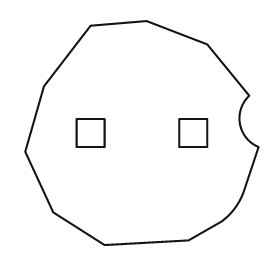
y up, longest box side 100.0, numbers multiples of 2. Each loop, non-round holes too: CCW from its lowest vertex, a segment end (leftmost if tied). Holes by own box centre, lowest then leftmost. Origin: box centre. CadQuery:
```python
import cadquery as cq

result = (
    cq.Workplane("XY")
    .moveTo(-16.0, -48.0)
    .lineTo(20.0, -46.0)
    .lineTo(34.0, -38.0)
    .threePointArc((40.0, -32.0), (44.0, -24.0))
    .lineTo(50.0, -6.0)
    .threePointArc((42.0, 4.0), (46.0, 16.0))
    .lineTo(28.0, 38.0)
    .lineTo(2.0, 48.0)
    .lineTo(-22.0, 46.0)
    .lineTo(-42.0, 20.0)
    .lineTo(-50.0, -8.0)
    .lineTo(-38.0, -34.0)
    .close()
    .moveTo(-28.0, -6.0)
    .lineTo(-16.0, -6.0)
    .lineTo(-16.0, 6.0)
    .lineTo(-28.0, 6.0)
    .close()
    .moveTo(16.0, -6.0)
    .lineTo(28.0, -6.0)
    .lineTo(28.0, 6.0)
    .lineTo(16.0, 6.0)
    .close()
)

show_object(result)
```